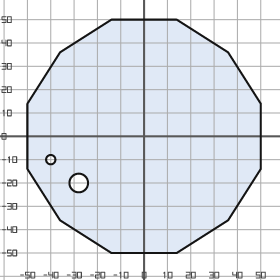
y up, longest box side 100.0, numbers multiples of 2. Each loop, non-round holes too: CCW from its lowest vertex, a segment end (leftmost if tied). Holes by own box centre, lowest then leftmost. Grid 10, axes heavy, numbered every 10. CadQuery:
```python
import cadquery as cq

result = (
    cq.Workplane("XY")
    .moveTo(-14.0, -50.0)
    .lineTo(14.0, -50.0)
    .lineTo(36.0, -36.0)
    .lineTo(50.0, -14.0)
    .lineTo(50.0, 14.0)
    .lineTo(36.0, 36.0)
    .lineTo(14.0, 50.0)
    .lineTo(-14.0, 50.0)
    .lineTo(-36.0, 36.0)
    .lineTo(-50.0, 14.0)
    .lineTo(-50.0, -14.0)
    .lineTo(-36.0, -36.0)
    .close()
    .moveTo(-28.0, -20.0)
    .circle(4.0)
    .moveTo(-40.0, -10.0)
    .circle(2.0)
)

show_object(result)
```